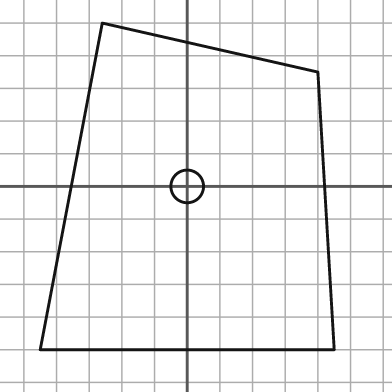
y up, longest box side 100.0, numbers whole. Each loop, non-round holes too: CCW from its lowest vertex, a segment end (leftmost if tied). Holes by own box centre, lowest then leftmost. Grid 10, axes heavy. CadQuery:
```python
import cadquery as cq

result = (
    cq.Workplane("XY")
    .moveTo(-45.0, -50.0)
    .lineTo(45.0, -50.0)
    .lineTo(40.0, 35.0)
    .lineTo(-26.0, 50.0)
    .close()
    .moveTo(0.0, 0.0)
    .circle(5.0)
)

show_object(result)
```